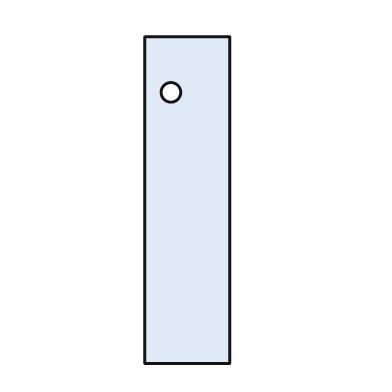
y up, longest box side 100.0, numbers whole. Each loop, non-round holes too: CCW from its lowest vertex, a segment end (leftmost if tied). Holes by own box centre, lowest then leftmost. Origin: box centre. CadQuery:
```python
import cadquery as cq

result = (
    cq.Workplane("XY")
    .moveTo(-13.0, -50.0)
    .lineTo(13.0, -50.0)
    .lineTo(13.0, 50.0)
    .lineTo(-13.0, 50.0)
    .close()
    .moveTo(-5.0, 33.0)
    .circle(3.0)
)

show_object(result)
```